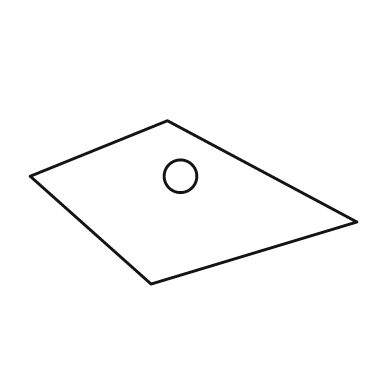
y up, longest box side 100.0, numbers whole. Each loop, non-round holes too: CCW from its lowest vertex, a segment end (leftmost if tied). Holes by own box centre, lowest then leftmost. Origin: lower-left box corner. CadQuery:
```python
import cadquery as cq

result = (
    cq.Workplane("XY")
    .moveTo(37.0, 0.0)
    .lineTo(100.0, 19.0)
    .lineTo(42.0, 50.0)
    .lineTo(0.0, 33.0)
    .close()
    .moveTo(46.0, 33.0)
    .circle(5.0)
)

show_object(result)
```